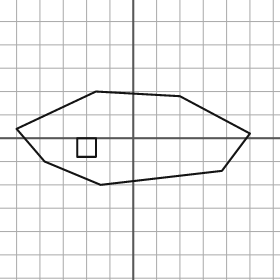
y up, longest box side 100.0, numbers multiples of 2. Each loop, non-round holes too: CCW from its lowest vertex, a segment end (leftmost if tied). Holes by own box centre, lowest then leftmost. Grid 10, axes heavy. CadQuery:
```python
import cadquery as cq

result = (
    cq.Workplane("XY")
    .moveTo(-14.0, -20.0)
    .lineTo(38.0, -14.0)
    .lineTo(50.0, 2.0)
    .lineTo(20.0, 18.0)
    .lineTo(-16.0, 20.0)
    .lineTo(-50.0, 4.0)
    .lineTo(-38.0, -10.0)
    .close()
    .moveTo(-24.0, -8.0)
    .lineTo(-16.0, -8.0)
    .lineTo(-16.0, 0.0)
    .lineTo(-24.0, 0.0)
    .close()
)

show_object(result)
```